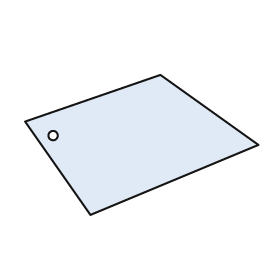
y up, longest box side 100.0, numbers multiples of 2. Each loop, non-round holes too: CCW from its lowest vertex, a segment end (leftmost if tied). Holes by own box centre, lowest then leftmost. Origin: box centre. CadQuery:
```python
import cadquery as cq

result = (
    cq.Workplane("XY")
    .moveTo(-22.0, -30.0)
    .lineTo(50.0, 0.0)
    .lineTo(8.0, 30.0)
    .lineTo(-50.0, 10.0)
    .close()
    .moveTo(-38.0, 4.0)
    .circle(2.0)
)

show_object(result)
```